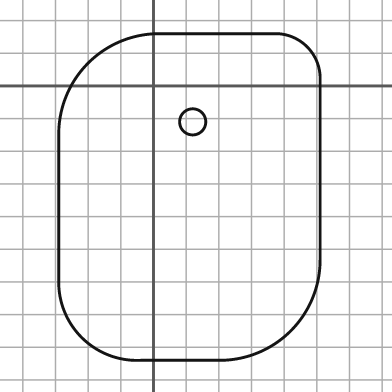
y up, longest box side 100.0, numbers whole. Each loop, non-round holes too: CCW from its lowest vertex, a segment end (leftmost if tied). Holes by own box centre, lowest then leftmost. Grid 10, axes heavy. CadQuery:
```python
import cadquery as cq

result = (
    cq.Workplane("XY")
    .moveTo(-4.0, -84.0)
    .lineTo(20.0, -84.0)
    .threePointArc((42.0, -75.0), (51.0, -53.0))
    .lineTo(51.0, 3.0)
    .threePointArc((47.0, 12.0), (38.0, 16.0))
    .lineTo(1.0, 16.0)
    .threePointArc((-20.0, 7.0), (-29.0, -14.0))
    .lineTo(-29.0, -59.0)
    .threePointArc((-22.0, -77.0), (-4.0, -84.0))
    .close()
    .moveTo(12.0, -11.0)
    .circle(4.0)
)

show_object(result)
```